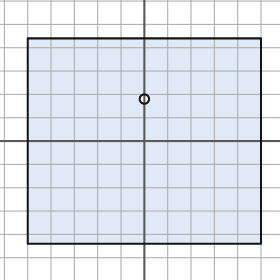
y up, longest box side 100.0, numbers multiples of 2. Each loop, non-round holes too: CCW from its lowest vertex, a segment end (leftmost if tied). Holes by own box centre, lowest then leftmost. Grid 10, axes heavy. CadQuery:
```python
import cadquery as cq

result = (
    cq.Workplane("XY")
    .moveTo(-50.0, -44.0)
    .lineTo(50.0, -44.0)
    .lineTo(50.0, 44.0)
    .lineTo(-50.0, 44.0)
    .close()
    .moveTo(0.0, 18.0)
    .circle(2.0)
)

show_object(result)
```